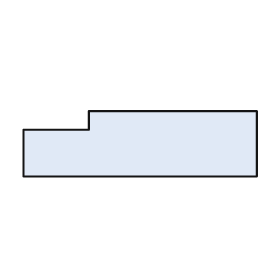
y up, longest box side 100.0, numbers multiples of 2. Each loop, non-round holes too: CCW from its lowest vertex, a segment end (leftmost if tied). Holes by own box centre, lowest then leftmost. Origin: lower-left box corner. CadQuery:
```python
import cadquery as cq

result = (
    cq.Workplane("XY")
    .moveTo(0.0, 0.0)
    .lineTo(100.0, 0.0)
    .lineTo(100.0, 28.0)
    .lineTo(28.0, 28.0)
    .lineTo(28.0, 20.0)
    .lineTo(0.0, 20.0)
    .close()
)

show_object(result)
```